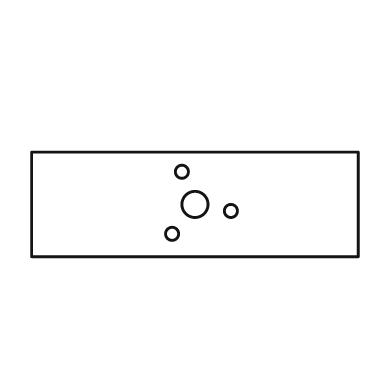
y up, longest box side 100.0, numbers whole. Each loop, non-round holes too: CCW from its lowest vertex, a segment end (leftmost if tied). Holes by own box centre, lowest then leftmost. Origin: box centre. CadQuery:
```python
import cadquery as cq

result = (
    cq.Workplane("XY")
    .moveTo(-50.0, -16.0)
    .lineTo(50.0, -16.0)
    .lineTo(50.0, 16.0)
    .lineTo(-50.0, 16.0)
    .close()
    .moveTo(-7.0, -9.0)
    .circle(2.0)
    .moveTo(11.0, -2.0)
    .circle(2.0)
    .moveTo(0.0, 0.0)
    .circle(4.0)
    .moveTo(-4.0, 10.0)
    .circle(2.0)
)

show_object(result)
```